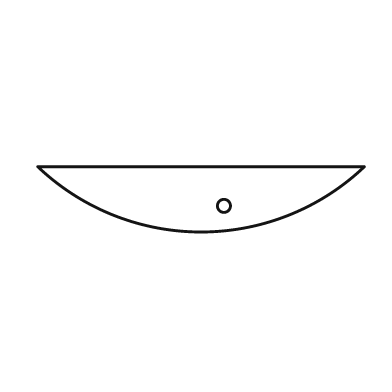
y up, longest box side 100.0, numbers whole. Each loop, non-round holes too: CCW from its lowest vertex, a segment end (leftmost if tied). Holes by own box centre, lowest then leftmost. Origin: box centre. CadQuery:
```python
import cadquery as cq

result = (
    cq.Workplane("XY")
    .moveTo(-50.0, 10.0)
    .threePointArc((0.0, -10.0), (50.0, 10.0))
    .close()
    .moveTo(7.0, -2.0)
    .circle(2.0)
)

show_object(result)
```